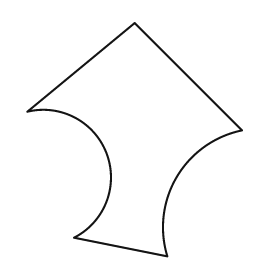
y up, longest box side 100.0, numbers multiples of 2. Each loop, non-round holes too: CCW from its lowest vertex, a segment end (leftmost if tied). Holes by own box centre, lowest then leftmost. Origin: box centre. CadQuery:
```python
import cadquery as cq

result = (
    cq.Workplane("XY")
    .moveTo(14.0, -50.0)
    .threePointArc((18.0, -16.0), (46.0, 4.0))
    .lineTo(0.0, 50.0)
    .lineTo(-46.0, 12.0)
    .threePointArc((-12.0, -6.0), (-26.0, -42.0))
    .close()
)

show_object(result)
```